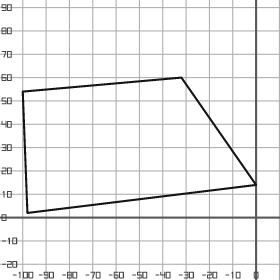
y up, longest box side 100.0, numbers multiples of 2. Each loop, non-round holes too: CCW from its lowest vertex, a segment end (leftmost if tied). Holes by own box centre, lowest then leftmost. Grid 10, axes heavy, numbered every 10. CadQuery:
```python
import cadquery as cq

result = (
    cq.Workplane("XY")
    .moveTo(-98.0, 2.0)
    .lineTo(0.0, 14.0)
    .lineTo(-32.0, 60.0)
    .lineTo(-100.0, 54.0)
    .close()
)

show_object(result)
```